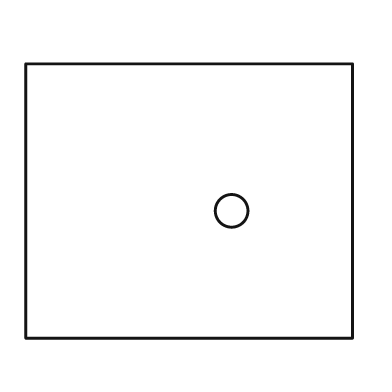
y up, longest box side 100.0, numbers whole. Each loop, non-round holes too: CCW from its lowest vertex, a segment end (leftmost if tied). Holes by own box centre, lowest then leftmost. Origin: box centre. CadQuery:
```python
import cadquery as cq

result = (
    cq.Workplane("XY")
    .moveTo(-50.0, -42.0)
    .lineTo(50.0, -42.0)
    .lineTo(50.0, 42.0)
    .lineTo(-50.0, 42.0)
    .close()
    .moveTo(13.0, -3.0)
    .circle(5.0)
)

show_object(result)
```